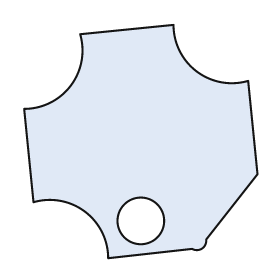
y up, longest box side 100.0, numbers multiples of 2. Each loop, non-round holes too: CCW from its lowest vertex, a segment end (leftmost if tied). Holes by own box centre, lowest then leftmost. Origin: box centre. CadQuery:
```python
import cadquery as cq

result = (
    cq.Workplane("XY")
    .moveTo(-14.0, -50.0)
    .lineTo(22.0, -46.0)
    .threePointArc((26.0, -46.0), (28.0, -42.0))
    .lineTo(50.0, -14.0)
    .lineTo(46.0, 26.0)
    .threePointArc((24.0, 30.0), (14.0, 50.0))
    .lineTo(-26.0, 46.0)
    .threePointArc((-30.0, 24.0), (-50.0, 14.0))
    .lineTo(-46.0, -26.0)
    .threePointArc((-24.0, -30.0), (-14.0, -50.0))
    .close()
    .moveTo(0.0, -34.0)
    .circle(10.0)
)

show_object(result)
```